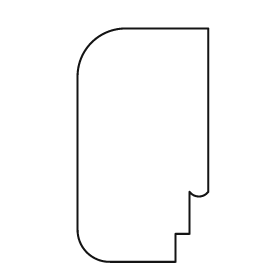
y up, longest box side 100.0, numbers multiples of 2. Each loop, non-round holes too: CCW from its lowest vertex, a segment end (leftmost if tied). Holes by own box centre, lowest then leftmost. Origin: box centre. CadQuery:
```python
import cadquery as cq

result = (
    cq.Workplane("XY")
    .moveTo(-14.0, -50.0)
    .lineTo(14.0, -50.0)
    .lineTo(14.0, -38.0)
    .lineTo(20.0, -38.0)
    .lineTo(20.0, -20.0)
    .threePointArc((24.0, -22.0), (28.0, -20.0))
    .lineTo(28.0, 50.0)
    .lineTo(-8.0, 50.0)
    .threePointArc((-22.0, 44.0), (-28.0, 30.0))
    .lineTo(-28.0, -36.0)
    .threePointArc((-24.0, -46.0), (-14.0, -50.0))
    .close()
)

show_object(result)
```